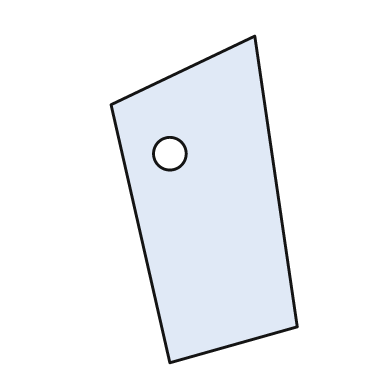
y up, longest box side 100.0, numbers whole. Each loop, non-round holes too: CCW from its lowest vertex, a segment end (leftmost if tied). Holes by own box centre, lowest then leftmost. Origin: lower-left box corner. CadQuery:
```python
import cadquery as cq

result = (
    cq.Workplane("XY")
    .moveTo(18.0, 0.0)
    .lineTo(57.0, 11.0)
    .lineTo(44.0, 100.0)
    .lineTo(0.0, 79.0)
    .close()
    .moveTo(18.0, 64.0)
    .circle(5.0)
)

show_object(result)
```